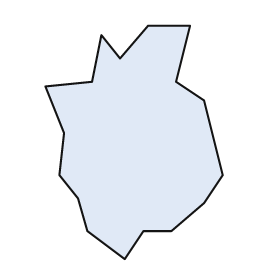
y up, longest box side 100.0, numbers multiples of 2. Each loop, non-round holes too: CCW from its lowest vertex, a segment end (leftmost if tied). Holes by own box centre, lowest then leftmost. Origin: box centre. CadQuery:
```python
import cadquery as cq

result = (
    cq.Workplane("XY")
    .moveTo(-4.0, -50.0)
    .lineTo(4.0, -38.0)
    .lineTo(16.0, -38.0)
    .lineTo(30.0, -26.0)
    .lineTo(38.0, -14.0)
    .lineTo(30.0, 18.0)
    .lineTo(18.0, 26.0)
    .lineTo(24.0, 50.0)
    .lineTo(6.0, 50.0)
    .lineTo(-6.0, 36.0)
    .lineTo(-14.0, 46.0)
    .lineTo(-18.0, 26.0)
    .lineTo(-38.0, 24.0)
    .lineTo(-30.0, 4.0)
    .lineTo(-32.0, -14.0)
    .lineTo(-24.0, -24.0)
    .lineTo(-20.0, -38.0)
    .close()
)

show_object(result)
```